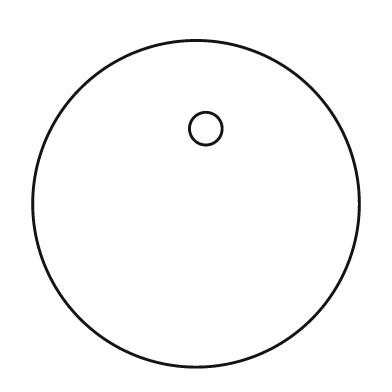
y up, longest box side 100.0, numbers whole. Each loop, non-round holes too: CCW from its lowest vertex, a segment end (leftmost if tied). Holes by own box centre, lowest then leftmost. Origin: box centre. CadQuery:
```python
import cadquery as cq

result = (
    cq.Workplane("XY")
    .moveTo(0.0, 0.0)
    .circle(50.0)
    .moveTo(3.0, 23.0)
    .circle(5.0)
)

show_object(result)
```